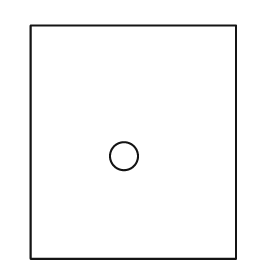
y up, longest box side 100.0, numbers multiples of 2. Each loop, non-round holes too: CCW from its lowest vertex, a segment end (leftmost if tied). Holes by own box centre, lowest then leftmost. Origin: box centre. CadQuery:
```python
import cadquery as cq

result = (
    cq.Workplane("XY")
    .moveTo(-44.0, -50.0)
    .lineTo(44.0, -50.0)
    .lineTo(44.0, 50.0)
    .lineTo(-44.0, 50.0)
    .close()
    .moveTo(-4.0, -6.0)
    .circle(6.0)
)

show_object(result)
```